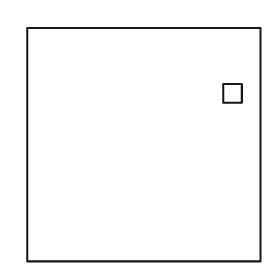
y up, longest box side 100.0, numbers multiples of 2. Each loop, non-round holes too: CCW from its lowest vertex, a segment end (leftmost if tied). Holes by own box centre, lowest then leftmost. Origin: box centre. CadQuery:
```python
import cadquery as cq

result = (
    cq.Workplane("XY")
    .moveTo(-50.0, -50.0)
    .lineTo(50.0, -50.0)
    .lineTo(50.0, 50.0)
    .lineTo(-50.0, 50.0)
    .close()
    .moveTo(34.0, 18.0)
    .lineTo(42.0, 18.0)
    .lineTo(42.0, 26.0)
    .lineTo(34.0, 26.0)
    .close()
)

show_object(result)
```